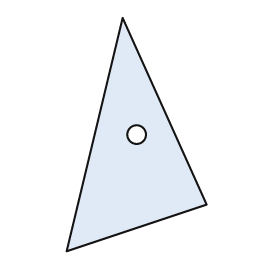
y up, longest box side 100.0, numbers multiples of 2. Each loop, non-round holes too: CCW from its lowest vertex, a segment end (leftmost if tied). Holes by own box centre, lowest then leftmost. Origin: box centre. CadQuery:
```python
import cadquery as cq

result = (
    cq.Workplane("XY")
    .moveTo(-30.0, -50.0)
    .lineTo(30.0, -30.0)
    .lineTo(-6.0, 50.0)
    .close()
    .moveTo(0.0, 0.0)
    .circle(4.0)
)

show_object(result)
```